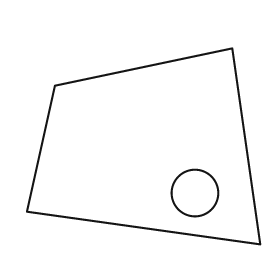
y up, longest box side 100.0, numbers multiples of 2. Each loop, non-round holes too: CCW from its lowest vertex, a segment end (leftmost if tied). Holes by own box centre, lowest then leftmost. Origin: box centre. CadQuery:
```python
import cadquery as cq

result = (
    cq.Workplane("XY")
    .moveTo(50.0, -42.0)
    .lineTo(38.0, 42.0)
    .lineTo(-38.0, 26.0)
    .lineTo(-50.0, -28.0)
    .close()
    .moveTo(22.0, -20.0)
    .circle(10.0)
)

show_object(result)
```